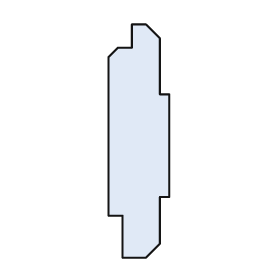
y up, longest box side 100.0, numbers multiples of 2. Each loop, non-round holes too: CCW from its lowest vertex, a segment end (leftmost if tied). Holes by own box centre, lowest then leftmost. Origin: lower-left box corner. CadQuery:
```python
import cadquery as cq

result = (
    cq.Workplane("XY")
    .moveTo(6.0, 0.0)
    .lineTo(16.0, 0.0)
    .lineTo(22.0, 6.0)
    .lineTo(22.0, 26.0)
    .lineTo(26.0, 26.0)
    .lineTo(26.0, 70.0)
    .lineTo(22.0, 70.0)
    .lineTo(22.0, 94.0)
    .lineTo(16.0, 100.0)
    .lineTo(10.0, 100.0)
    .lineTo(10.0, 90.0)
    .lineTo(4.0, 90.0)
    .lineTo(0.0, 86.0)
    .lineTo(0.0, 18.0)
    .lineTo(6.0, 18.0)
    .close()
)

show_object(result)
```